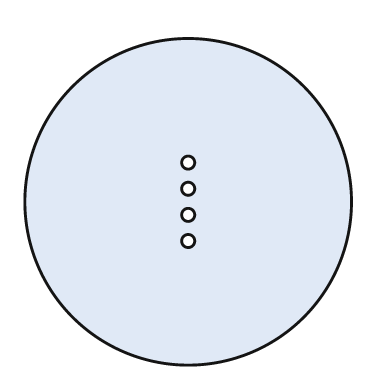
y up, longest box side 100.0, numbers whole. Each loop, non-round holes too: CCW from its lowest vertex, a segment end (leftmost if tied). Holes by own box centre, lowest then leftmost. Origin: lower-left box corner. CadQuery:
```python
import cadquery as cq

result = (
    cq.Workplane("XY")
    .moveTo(50.0, 50.0)
    .circle(50.0)
    .moveTo(50.0, 38.0)
    .circle(2.0)
    .moveTo(50.0, 46.0)
    .circle(2.0)
    .moveTo(50.0, 54.0)
    .circle(2.0)
    .moveTo(50.0, 62.0)
    .circle(2.0)
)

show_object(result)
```